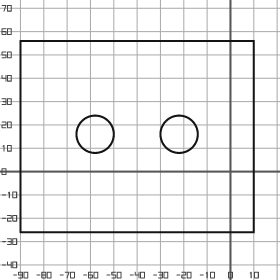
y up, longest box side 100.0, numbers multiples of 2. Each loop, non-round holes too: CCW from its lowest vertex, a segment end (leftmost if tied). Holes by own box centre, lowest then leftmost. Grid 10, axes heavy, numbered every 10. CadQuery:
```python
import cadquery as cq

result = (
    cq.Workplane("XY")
    .moveTo(-90.0, -26.0)
    .lineTo(10.0, -26.0)
    .lineTo(10.0, 56.0)
    .lineTo(-90.0, 56.0)
    .close()
    .moveTo(-58.0, 16.0)
    .circle(8.0)
    .moveTo(-22.0, 16.0)
    .circle(8.0)
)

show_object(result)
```